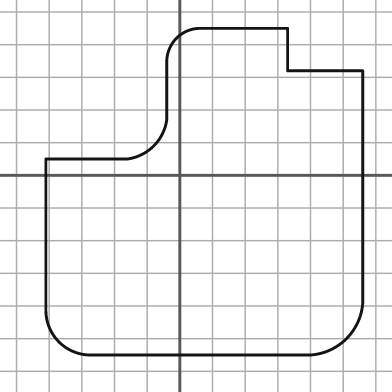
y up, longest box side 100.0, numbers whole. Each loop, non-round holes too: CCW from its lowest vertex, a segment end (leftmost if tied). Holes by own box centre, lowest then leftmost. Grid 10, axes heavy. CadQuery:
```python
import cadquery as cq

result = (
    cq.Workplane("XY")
    .moveTo(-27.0, -55.0)
    .lineTo(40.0, -55.0)
    .threePointArc((51.0, -50.0), (56.0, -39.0))
    .lineTo(56.0, 32.0)
    .lineTo(33.0, 32.0)
    .lineTo(33.0, 45.0)
    .lineTo(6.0, 45.0)
    .threePointArc((-1.0, 42.0), (-4.0, 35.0))
    .lineTo(-4.0, 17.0)
    .threePointArc((-8.0, 9.0), (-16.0, 5.0))
    .lineTo(-41.0, 5.0)
    .lineTo(-41.0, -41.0)
    .threePointArc((-37.0, -51.0), (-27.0, -55.0))
    .close()
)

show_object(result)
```